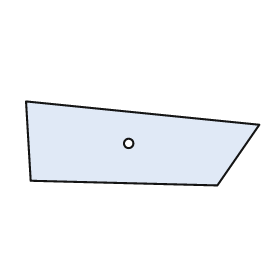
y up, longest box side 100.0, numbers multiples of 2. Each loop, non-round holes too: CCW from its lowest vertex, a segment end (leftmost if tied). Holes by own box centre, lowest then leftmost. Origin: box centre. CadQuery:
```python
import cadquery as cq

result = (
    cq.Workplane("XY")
    .moveTo(32.0, -18.0)
    .lineTo(50.0, 8.0)
    .lineTo(-50.0, 18.0)
    .lineTo(-48.0, -16.0)
    .close()
    .moveTo(-6.0, 0.0)
    .circle(2.0)
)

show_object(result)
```